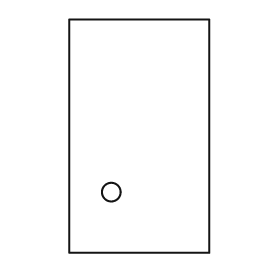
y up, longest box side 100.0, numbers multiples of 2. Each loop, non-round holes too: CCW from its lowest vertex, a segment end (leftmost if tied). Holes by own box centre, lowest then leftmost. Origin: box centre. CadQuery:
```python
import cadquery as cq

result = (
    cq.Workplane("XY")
    .moveTo(-30.0, -50.0)
    .lineTo(30.0, -50.0)
    .lineTo(30.0, 50.0)
    .lineTo(-30.0, 50.0)
    .close()
    .moveTo(-12.0, -24.0)
    .circle(4.0)
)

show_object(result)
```